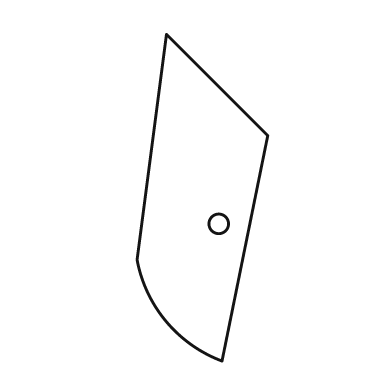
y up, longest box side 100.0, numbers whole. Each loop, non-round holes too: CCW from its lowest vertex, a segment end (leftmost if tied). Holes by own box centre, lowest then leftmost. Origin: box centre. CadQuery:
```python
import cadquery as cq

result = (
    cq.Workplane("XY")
    .moveTo(6.0, -50.0)
    .lineTo(20.0, 19.0)
    .lineTo(-11.0, 50.0)
    .lineTo(-20.0, -19.0)
    .threePointArc((-11.0, -38.0), (6.0, -50.0))
    .close()
    .moveTo(5.0, -8.0)
    .circle(3.0)
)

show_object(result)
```